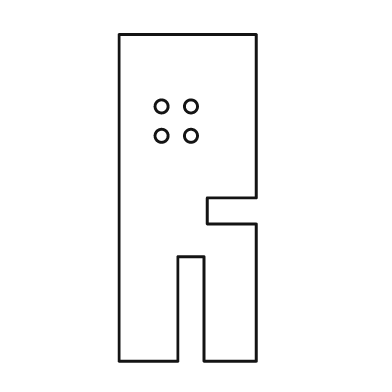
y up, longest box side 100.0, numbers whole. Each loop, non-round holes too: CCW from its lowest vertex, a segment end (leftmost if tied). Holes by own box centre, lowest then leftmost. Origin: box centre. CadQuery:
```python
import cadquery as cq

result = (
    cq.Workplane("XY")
    .moveTo(-21.0, -50.0)
    .lineTo(-3.0, -50.0)
    .lineTo(-3.0, -18.0)
    .lineTo(5.0, -18.0)
    .lineTo(5.0, -50.0)
    .lineTo(21.0, -50.0)
    .lineTo(21.0, -8.0)
    .lineTo(6.0, -8.0)
    .lineTo(6.0, 0.0)
    .lineTo(21.0, 0.0)
    .lineTo(21.0, 50.0)
    .lineTo(-21.0, 50.0)
    .close()
    .moveTo(-8.0, 19.0)
    .circle(2.0)
    .moveTo(1.0, 19.0)
    .circle(2.0)
    .moveTo(-8.0, 28.0)
    .circle(2.0)
    .moveTo(1.0, 28.0)
    .circle(2.0)
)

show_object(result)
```